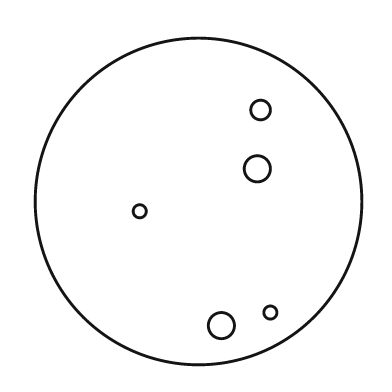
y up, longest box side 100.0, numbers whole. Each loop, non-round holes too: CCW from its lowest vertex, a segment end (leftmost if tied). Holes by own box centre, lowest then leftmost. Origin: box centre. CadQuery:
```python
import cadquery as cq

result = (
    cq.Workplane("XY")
    .moveTo(0.0, 0.0)
    .circle(50.0)
    .moveTo(7.0, -38.0)
    .circle(4.0)
    .moveTo(22.0, -34.0)
    .circle(2.0)
    .moveTo(-18.0, -3.0)
    .circle(2.0)
    .moveTo(18.0, 10.0)
    .circle(4.0)
    .moveTo(19.0, 28.0)
    .circle(3.0)
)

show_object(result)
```